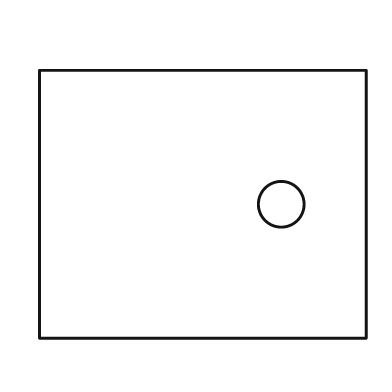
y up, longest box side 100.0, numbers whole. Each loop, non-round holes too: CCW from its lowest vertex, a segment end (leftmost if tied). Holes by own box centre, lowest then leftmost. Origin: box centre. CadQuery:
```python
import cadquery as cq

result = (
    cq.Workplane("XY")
    .moveTo(-50.0, -41.0)
    .lineTo(50.0, -41.0)
    .lineTo(50.0, 41.0)
    .lineTo(-50.0, 41.0)
    .close()
    .moveTo(24.0, 0.0)
    .circle(7.0)
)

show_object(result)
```